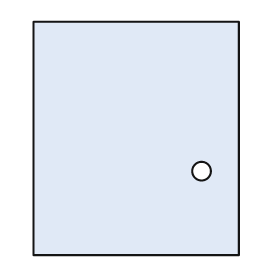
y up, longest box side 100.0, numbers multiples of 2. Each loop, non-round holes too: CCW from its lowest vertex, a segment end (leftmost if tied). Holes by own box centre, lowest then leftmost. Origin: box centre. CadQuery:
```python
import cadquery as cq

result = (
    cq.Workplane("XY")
    .moveTo(-44.0, -50.0)
    .lineTo(44.0, -50.0)
    .lineTo(44.0, 50.0)
    .lineTo(-44.0, 50.0)
    .close()
    .moveTo(28.0, -14.0)
    .circle(4.0)
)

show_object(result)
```